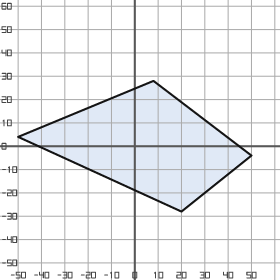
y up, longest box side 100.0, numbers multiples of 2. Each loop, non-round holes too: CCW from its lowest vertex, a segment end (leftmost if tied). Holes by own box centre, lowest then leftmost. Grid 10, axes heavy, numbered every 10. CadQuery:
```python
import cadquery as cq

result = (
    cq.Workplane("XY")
    .moveTo(20.0, -28.0)
    .lineTo(50.0, -4.0)
    .lineTo(8.0, 28.0)
    .lineTo(-50.0, 4.0)
    .close()
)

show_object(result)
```